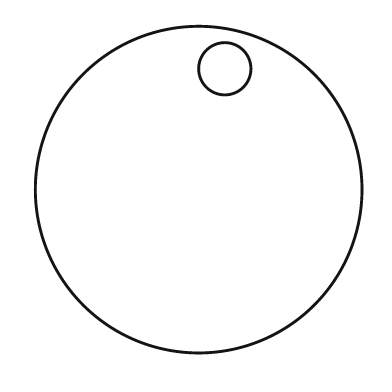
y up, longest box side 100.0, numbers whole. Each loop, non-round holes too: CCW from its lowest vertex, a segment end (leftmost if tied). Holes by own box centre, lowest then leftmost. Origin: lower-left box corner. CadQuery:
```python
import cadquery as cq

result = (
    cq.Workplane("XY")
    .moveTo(50.0, 50.0)
    .circle(50.0)
    .moveTo(58.0, 87.0)
    .circle(8.0)
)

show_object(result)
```